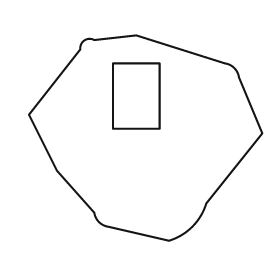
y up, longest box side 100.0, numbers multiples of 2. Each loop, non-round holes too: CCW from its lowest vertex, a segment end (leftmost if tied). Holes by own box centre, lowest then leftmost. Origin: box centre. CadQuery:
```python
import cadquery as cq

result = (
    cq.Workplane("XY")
    .moveTo(10.0, -44.0)
    .threePointArc((20.0, -38.0), (26.0, -28.0))
    .lineTo(50.0, 2.0)
    .lineTo(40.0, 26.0)
    .threePointArc((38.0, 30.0), (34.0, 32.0))
    .lineTo(-4.0, 44.0)
    .lineTo(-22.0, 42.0)
    .threePointArc((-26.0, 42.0), (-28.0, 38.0))
    .lineTo(-50.0, 10.0)
    .lineTo(-38.0, -14.0)
    .lineTo(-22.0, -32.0)
    .threePointArc((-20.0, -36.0), (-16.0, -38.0))
    .close()
    .moveTo(-14.0, 4.0)
    .lineTo(6.0, 4.0)
    .lineTo(6.0, 32.0)
    .lineTo(-14.0, 32.0)
    .close()
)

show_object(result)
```